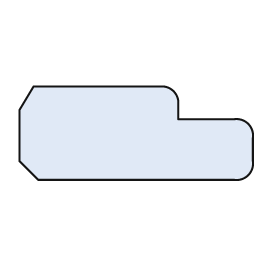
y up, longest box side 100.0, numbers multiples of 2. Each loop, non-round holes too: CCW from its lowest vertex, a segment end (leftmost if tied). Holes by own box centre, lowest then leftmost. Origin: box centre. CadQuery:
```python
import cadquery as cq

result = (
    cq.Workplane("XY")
    .moveTo(-42.0, -20.0)
    .lineTo(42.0, -20.0)
    .threePointArc((48.0, -18.0), (50.0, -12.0))
    .lineTo(50.0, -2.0)
    .threePointArc((48.0, 4.0), (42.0, 6.0))
    .lineTo(18.0, 6.0)
    .lineTo(18.0, 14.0)
    .threePointArc((16.0, 18.0), (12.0, 20.0))
    .lineTo(-44.0, 20.0)
    .lineTo(-50.0, 10.0)
    .lineTo(-50.0, -12.0)
    .close()
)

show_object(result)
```